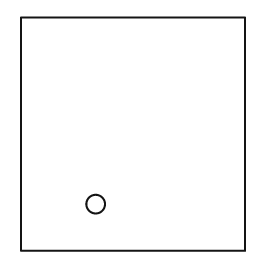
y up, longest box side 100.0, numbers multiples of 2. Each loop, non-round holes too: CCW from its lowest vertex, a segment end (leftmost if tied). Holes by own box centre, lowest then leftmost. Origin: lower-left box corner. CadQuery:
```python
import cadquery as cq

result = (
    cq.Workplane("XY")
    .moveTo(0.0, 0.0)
    .lineTo(96.0, 0.0)
    .lineTo(96.0, 100.0)
    .lineTo(0.0, 100.0)
    .close()
    .moveTo(32.0, 20.0)
    .circle(4.0)
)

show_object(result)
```